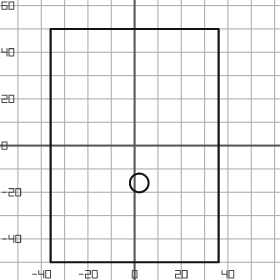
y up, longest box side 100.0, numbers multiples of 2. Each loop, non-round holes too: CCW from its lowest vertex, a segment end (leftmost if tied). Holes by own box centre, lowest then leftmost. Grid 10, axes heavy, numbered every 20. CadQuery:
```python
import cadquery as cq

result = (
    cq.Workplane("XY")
    .moveTo(-36.0, -50.0)
    .lineTo(36.0, -50.0)
    .lineTo(36.0, 50.0)
    .lineTo(-36.0, 50.0)
    .close()
    .moveTo(2.0, -16.0)
    .circle(4.0)
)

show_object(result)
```